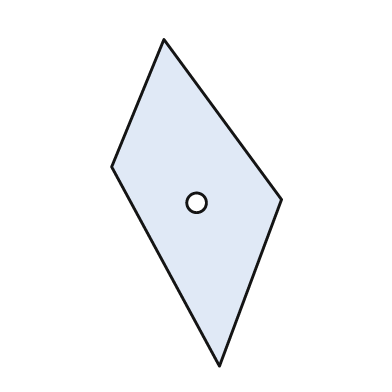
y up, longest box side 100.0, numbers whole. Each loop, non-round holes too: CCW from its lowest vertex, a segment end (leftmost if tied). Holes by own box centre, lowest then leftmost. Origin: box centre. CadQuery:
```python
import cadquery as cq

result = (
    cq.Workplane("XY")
    .moveTo(7.0, -50.0)
    .lineTo(26.0, 1.0)
    .lineTo(-10.0, 50.0)
    .lineTo(-26.0, 11.0)
    .close()
    .moveTo(0.0, 0.0)
    .circle(3.0)
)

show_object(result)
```